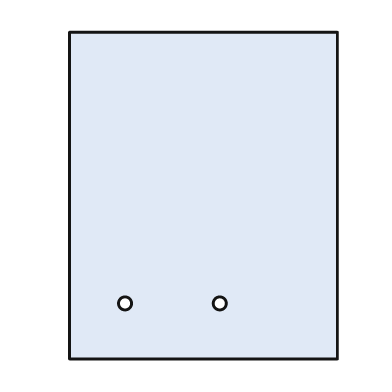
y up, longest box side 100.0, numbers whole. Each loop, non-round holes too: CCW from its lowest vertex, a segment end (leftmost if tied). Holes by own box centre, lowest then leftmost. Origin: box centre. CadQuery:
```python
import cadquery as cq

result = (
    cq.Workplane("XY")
    .moveTo(-41.0, -50.0)
    .lineTo(41.0, -50.0)
    .lineTo(41.0, 50.0)
    .lineTo(-41.0, 50.0)
    .close()
    .moveTo(-24.0, -33.0)
    .circle(2.0)
    .moveTo(5.0, -33.0)
    .circle(2.0)
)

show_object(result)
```